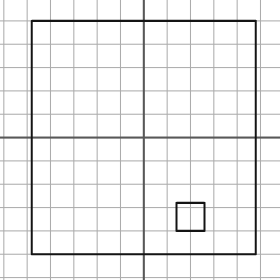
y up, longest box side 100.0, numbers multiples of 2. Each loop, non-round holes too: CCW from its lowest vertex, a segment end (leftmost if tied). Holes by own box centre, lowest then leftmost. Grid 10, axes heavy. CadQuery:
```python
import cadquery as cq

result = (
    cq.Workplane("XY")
    .moveTo(-48.0, -50.0)
    .lineTo(48.0, -50.0)
    .lineTo(48.0, 50.0)
    .lineTo(-48.0, 50.0)
    .close()
    .moveTo(14.0, -40.0)
    .lineTo(26.0, -40.0)
    .lineTo(26.0, -28.0)
    .lineTo(14.0, -28.0)
    .close()
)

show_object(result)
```